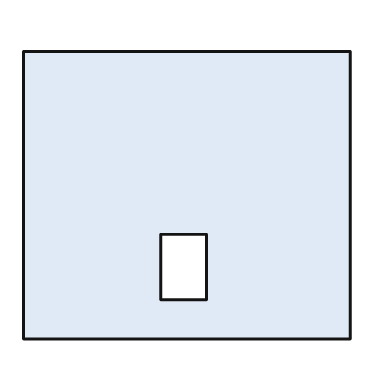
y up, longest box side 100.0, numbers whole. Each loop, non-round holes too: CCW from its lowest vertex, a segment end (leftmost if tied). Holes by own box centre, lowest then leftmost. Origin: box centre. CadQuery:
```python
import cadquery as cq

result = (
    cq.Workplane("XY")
    .moveTo(-50.0, -44.0)
    .lineTo(50.0, -44.0)
    .lineTo(50.0, 44.0)
    .lineTo(-50.0, 44.0)
    .close()
    .moveTo(-8.0, -32.0)
    .lineTo(6.0, -32.0)
    .lineTo(6.0, -12.0)
    .lineTo(-8.0, -12.0)
    .close()
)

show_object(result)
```